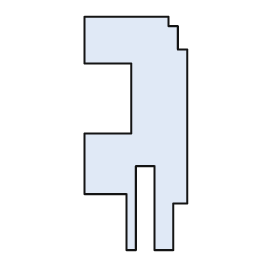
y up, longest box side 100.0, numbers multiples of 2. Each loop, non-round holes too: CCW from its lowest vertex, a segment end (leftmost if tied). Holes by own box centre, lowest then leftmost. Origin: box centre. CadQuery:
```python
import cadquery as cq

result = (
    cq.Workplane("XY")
    .moveTo(-4.0, -50.0)
    .lineTo(0.0, -50.0)
    .lineTo(0.0, -14.0)
    .lineTo(8.0, -14.0)
    .lineTo(8.0, -50.0)
    .lineTo(16.0, -50.0)
    .lineTo(16.0, -30.0)
    .lineTo(22.0, -30.0)
    .lineTo(22.0, 36.0)
    .lineTo(18.0, 36.0)
    .lineTo(18.0, 46.0)
    .lineTo(14.0, 46.0)
    .lineTo(14.0, 50.0)
    .lineTo(-22.0, 50.0)
    .lineTo(-22.0, 30.0)
    .lineTo(-2.0, 30.0)
    .lineTo(-2.0, 0.0)
    .lineTo(-22.0, 0.0)
    .lineTo(-22.0, -26.0)
    .lineTo(-4.0, -26.0)
    .close()
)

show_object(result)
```